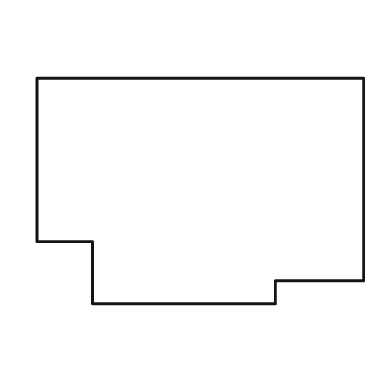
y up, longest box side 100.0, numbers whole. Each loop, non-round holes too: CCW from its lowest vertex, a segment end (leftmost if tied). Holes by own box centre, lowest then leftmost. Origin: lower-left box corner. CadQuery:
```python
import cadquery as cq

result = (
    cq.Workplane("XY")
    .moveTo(17.0, 0.0)
    .lineTo(73.0, 0.0)
    .lineTo(73.0, 7.0)
    .lineTo(100.0, 7.0)
    .lineTo(100.0, 69.0)
    .lineTo(0.0, 69.0)
    .lineTo(0.0, 19.0)
    .lineTo(17.0, 19.0)
    .close()
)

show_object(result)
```